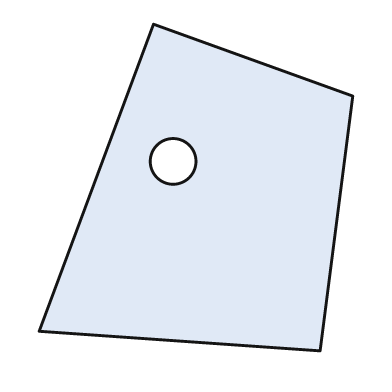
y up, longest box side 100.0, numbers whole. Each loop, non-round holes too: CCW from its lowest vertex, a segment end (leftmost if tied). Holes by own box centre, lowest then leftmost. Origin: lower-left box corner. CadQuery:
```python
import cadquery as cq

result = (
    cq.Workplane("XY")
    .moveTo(86.0, 0.0)
    .lineTo(96.0, 78.0)
    .lineTo(35.0, 100.0)
    .lineTo(0.0, 6.0)
    .close()
    .moveTo(41.0, 58.0)
    .circle(7.0)
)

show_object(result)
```